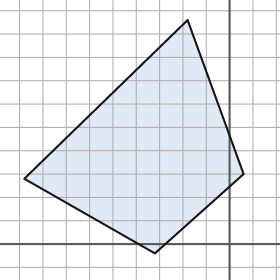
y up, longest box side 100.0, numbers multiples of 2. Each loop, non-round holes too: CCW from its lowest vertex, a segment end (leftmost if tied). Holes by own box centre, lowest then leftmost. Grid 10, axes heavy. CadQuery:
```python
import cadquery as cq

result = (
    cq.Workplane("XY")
    .moveTo(-32.0, -4.0)
    .lineTo(6.0, 30.0)
    .lineTo(-18.0, 96.0)
    .lineTo(-88.0, 28.0)
    .close()
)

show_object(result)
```